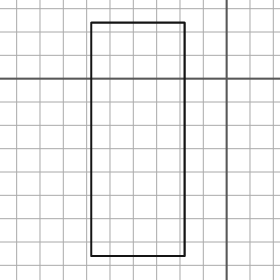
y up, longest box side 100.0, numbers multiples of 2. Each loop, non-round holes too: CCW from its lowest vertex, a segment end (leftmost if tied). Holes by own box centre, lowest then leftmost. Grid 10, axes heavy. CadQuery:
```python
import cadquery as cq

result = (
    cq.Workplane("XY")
    .moveTo(-58.0, -76.0)
    .lineTo(-18.0, -76.0)
    .lineTo(-18.0, 24.0)
    .lineTo(-58.0, 24.0)
    .close()
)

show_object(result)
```